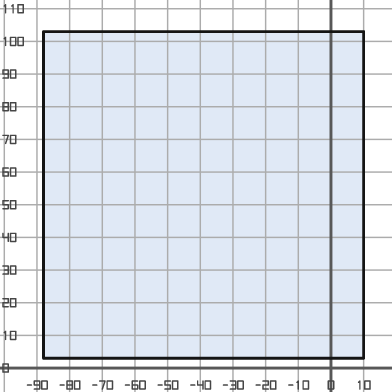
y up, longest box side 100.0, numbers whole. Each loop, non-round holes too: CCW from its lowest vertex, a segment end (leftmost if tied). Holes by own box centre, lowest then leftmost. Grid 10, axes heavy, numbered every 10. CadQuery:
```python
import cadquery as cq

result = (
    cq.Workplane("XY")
    .moveTo(-88.0, 3.0)
    .lineTo(10.0, 3.0)
    .lineTo(10.0, 103.0)
    .lineTo(-88.0, 103.0)
    .close()
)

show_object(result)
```